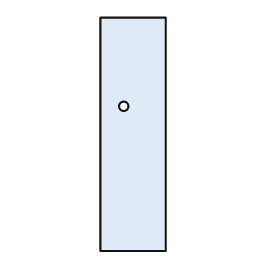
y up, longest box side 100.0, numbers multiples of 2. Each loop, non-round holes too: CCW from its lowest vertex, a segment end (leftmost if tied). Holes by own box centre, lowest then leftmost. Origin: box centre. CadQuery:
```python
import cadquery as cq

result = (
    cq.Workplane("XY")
    .moveTo(-14.0, -50.0)
    .lineTo(14.0, -50.0)
    .lineTo(14.0, 50.0)
    .lineTo(-14.0, 50.0)
    .close()
    .moveTo(-4.0, 12.0)
    .circle(2.0)
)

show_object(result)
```